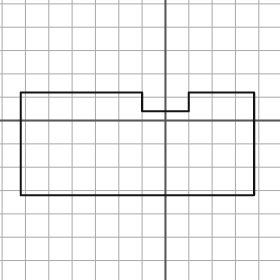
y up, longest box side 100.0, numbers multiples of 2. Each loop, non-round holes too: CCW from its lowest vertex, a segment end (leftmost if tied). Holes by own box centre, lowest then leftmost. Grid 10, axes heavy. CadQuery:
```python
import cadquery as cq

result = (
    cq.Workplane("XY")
    .moveTo(-62.0, -32.0)
    .lineTo(38.0, -32.0)
    .lineTo(38.0, 12.0)
    .lineTo(10.0, 12.0)
    .lineTo(10.0, 4.0)
    .lineTo(-10.0, 4.0)
    .lineTo(-10.0, 12.0)
    .lineTo(-62.0, 12.0)
    .close()
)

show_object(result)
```